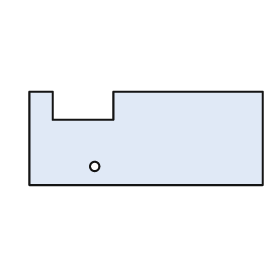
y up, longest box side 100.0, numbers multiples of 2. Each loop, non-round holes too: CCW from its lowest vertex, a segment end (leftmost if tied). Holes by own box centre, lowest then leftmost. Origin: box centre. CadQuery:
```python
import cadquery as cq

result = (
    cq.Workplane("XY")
    .moveTo(-50.0, -20.0)
    .lineTo(50.0, -20.0)
    .lineTo(50.0, 20.0)
    .lineTo(-14.0, 20.0)
    .lineTo(-14.0, 8.0)
    .lineTo(-40.0, 8.0)
    .lineTo(-40.0, 20.0)
    .lineTo(-50.0, 20.0)
    .close()
    .moveTo(-22.0, -12.0)
    .circle(2.0)
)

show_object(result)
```